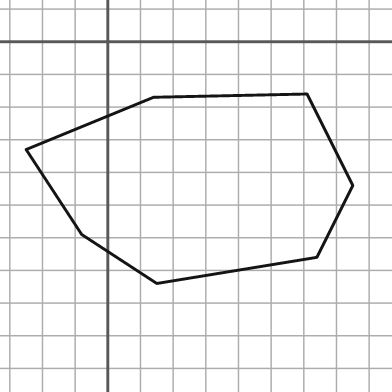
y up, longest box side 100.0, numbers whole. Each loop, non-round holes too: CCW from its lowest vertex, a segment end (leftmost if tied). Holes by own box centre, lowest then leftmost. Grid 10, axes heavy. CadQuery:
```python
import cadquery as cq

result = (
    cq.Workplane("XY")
    .moveTo(15.0, -74.0)
    .lineTo(64.0, -66.0)
    .lineTo(75.0, -44.0)
    .lineTo(61.0, -16.0)
    .lineTo(14.0, -17.0)
    .lineTo(-25.0, -33.0)
    .lineTo(-8.0, -59.0)
    .close()
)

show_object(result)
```